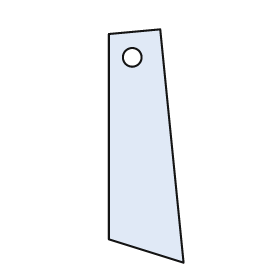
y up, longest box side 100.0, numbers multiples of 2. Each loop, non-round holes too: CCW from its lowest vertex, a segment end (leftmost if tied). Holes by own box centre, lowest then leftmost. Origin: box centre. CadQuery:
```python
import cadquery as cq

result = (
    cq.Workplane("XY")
    .moveTo(16.0, -50.0)
    .lineTo(6.0, 50.0)
    .lineTo(-16.0, 48.0)
    .lineTo(-16.0, -40.0)
    .close()
    .moveTo(-6.0, 38.0)
    .circle(4.0)
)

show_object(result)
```